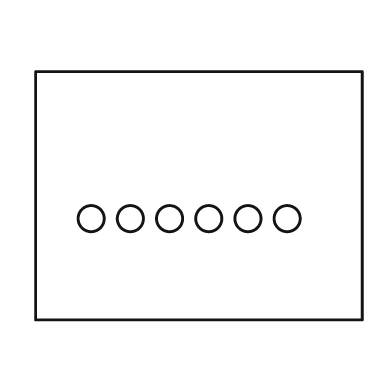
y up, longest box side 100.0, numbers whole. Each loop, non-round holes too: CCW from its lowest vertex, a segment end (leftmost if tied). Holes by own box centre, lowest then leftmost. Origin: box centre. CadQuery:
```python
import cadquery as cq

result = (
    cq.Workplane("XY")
    .moveTo(-50.0, -38.0)
    .lineTo(50.0, -38.0)
    .lineTo(50.0, 38.0)
    .lineTo(-50.0, 38.0)
    .close()
    .moveTo(-33.0, -7.0)
    .circle(4.0)
    .moveTo(-21.0, -7.0)
    .circle(4.0)
    .moveTo(-9.0, -7.0)
    .circle(4.0)
    .moveTo(3.0, -7.0)
    .circle(4.0)
    .moveTo(15.0, -7.0)
    .circle(4.0)
    .moveTo(27.0, -7.0)
    .circle(4.0)
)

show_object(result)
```